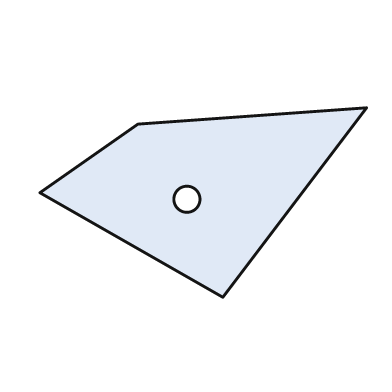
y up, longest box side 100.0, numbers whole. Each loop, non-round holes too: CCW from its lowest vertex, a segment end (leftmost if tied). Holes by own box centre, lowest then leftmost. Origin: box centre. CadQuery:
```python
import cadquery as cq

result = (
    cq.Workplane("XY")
    .moveTo(6.0, -29.0)
    .lineTo(50.0, 29.0)
    .lineTo(-20.0, 24.0)
    .lineTo(-50.0, 3.0)
    .close()
    .moveTo(-5.0, 1.0)
    .circle(4.0)
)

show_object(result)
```